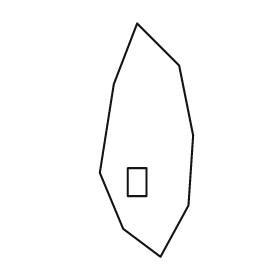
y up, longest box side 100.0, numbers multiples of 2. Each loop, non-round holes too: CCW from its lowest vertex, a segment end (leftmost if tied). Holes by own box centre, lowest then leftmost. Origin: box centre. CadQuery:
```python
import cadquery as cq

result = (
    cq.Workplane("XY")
    .moveTo(6.0, -50.0)
    .lineTo(18.0, -28.0)
    .lineTo(20.0, 2.0)
    .lineTo(14.0, 32.0)
    .lineTo(-4.0, 50.0)
    .lineTo(-14.0, 24.0)
    .lineTo(-20.0, -14.0)
    .lineTo(-10.0, -38.0)
    .close()
    .moveTo(-8.0, -24.0)
    .lineTo(0.0, -24.0)
    .lineTo(0.0, -12.0)
    .lineTo(-8.0, -12.0)
    .close()
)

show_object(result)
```